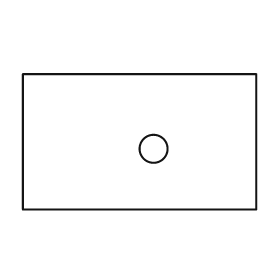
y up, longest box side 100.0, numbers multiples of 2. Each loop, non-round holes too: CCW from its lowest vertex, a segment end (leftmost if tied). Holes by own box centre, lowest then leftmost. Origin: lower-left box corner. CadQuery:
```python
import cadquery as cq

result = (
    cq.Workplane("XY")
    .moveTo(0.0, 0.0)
    .lineTo(100.0, 0.0)
    .lineTo(100.0, 58.0)
    .lineTo(0.0, 58.0)
    .close()
    .moveTo(56.0, 26.0)
    .circle(6.0)
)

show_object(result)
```